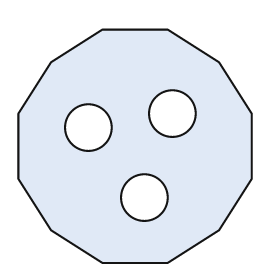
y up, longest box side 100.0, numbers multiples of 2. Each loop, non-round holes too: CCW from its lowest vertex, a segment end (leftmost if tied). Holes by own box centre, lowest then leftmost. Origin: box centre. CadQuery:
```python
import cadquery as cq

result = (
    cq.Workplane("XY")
    .moveTo(-14.0, -50.0)
    .lineTo(14.0, -50.0)
    .lineTo(36.0, -36.0)
    .lineTo(50.0, -14.0)
    .lineTo(50.0, 14.0)
    .lineTo(36.0, 36.0)
    .lineTo(14.0, 50.0)
    .lineTo(-14.0, 50.0)
    .lineTo(-36.0, 36.0)
    .lineTo(-50.0, 14.0)
    .lineTo(-50.0, -14.0)
    .lineTo(-36.0, -36.0)
    .close()
    .moveTo(4.0, -22.0)
    .circle(10.0)
    .moveTo(-20.0, 8.0)
    .circle(10.0)
    .moveTo(16.0, 14.0)
    .circle(10.0)
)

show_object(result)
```